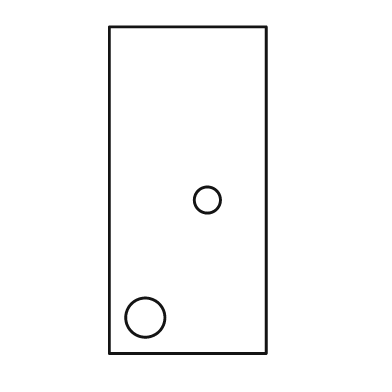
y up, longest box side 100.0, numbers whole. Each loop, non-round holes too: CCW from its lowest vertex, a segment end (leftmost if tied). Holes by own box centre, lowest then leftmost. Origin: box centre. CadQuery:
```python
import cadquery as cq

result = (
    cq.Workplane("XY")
    .moveTo(-24.0, -50.0)
    .lineTo(24.0, -50.0)
    .lineTo(24.0, 50.0)
    .lineTo(-24.0, 50.0)
    .close()
    .moveTo(-13.0, -39.0)
    .circle(6.0)
    .moveTo(6.0, -3.0)
    .circle(4.0)
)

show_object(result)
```